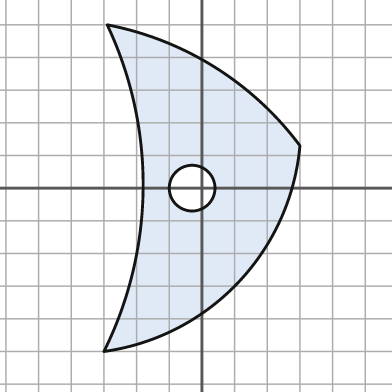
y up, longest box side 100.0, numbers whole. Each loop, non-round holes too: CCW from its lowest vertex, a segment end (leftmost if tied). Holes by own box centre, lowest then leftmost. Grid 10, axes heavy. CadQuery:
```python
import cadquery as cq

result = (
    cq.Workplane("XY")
    .moveTo(-30.0, -50.0)
    .threePointArc((11.0, -29.0), (30.0, 13.0))
    .threePointArc((4.0, 37.0), (-29.0, 50.0))
    .threePointArc((-18.0, 0.0), (-30.0, -50.0))
    .close()
    .moveTo(-3.0, 0.0)
    .circle(7.0)
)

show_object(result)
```